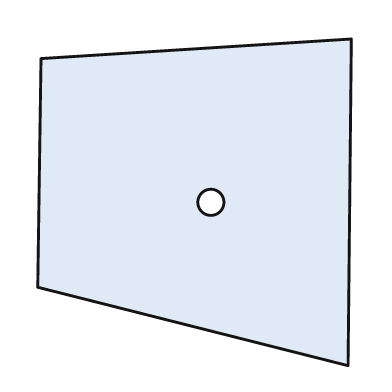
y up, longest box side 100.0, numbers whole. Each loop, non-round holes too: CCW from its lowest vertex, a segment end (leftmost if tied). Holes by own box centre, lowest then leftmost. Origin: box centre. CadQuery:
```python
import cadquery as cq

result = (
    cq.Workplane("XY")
    .moveTo(47.0, -50.0)
    .lineTo(48.0, 50.0)
    .lineTo(-47.0, 44.0)
    .lineTo(-48.0, -26.0)
    .close()
    .moveTo(5.0, 0.0)
    .circle(4.0)
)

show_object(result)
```